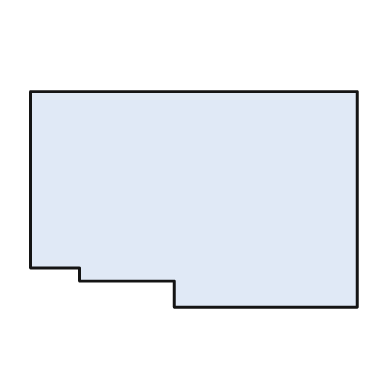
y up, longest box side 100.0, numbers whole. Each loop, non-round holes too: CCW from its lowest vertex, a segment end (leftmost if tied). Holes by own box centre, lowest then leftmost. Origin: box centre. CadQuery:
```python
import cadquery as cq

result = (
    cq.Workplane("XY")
    .moveTo(-6.0, -33.0)
    .lineTo(50.0, -33.0)
    .lineTo(50.0, 33.0)
    .lineTo(-50.0, 33.0)
    .lineTo(-50.0, -21.0)
    .lineTo(-35.0, -21.0)
    .lineTo(-35.0, -25.0)
    .lineTo(-6.0, -25.0)
    .close()
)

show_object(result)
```